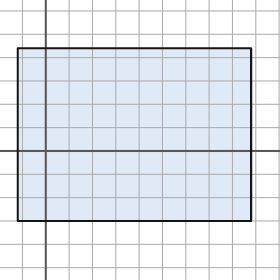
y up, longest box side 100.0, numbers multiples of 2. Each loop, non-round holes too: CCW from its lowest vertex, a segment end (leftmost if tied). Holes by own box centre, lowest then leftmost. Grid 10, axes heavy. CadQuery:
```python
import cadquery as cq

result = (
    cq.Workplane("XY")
    .moveTo(-12.0, -30.0)
    .lineTo(88.0, -30.0)
    .lineTo(88.0, 44.0)
    .lineTo(-12.0, 44.0)
    .close()
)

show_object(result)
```